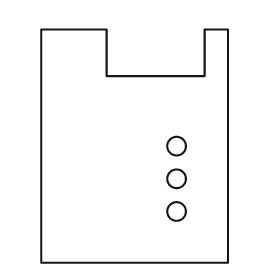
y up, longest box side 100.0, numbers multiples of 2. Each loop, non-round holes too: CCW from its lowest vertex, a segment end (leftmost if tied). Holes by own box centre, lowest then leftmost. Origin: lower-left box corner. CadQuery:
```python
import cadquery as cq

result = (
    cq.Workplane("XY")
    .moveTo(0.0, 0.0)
    .lineTo(80.0, 0.0)
    .lineTo(80.0, 100.0)
    .lineTo(70.0, 100.0)
    .lineTo(70.0, 80.0)
    .lineTo(28.0, 80.0)
    .lineTo(28.0, 100.0)
    .lineTo(0.0, 100.0)
    .close()
    .moveTo(58.0, 22.0)
    .circle(4.0)
    .moveTo(58.0, 36.0)
    .circle(4.0)
    .moveTo(58.0, 50.0)
    .circle(4.0)
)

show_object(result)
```